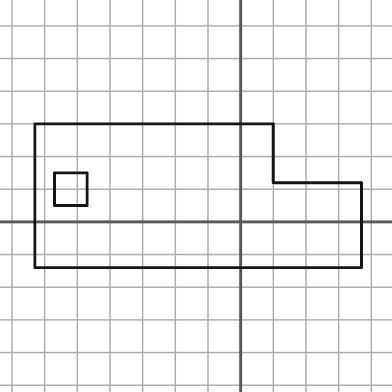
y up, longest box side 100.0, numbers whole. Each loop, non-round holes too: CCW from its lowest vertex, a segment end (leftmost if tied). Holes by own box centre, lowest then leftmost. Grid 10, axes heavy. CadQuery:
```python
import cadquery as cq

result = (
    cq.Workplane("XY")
    .moveTo(-63.0, -14.0)
    .lineTo(37.0, -14.0)
    .lineTo(37.0, 12.0)
    .lineTo(10.0, 12.0)
    .lineTo(10.0, 30.0)
    .lineTo(-63.0, 30.0)
    .close()
    .moveTo(-57.0, 5.0)
    .lineTo(-47.0, 5.0)
    .lineTo(-47.0, 15.0)
    .lineTo(-57.0, 15.0)
    .close()
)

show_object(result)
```